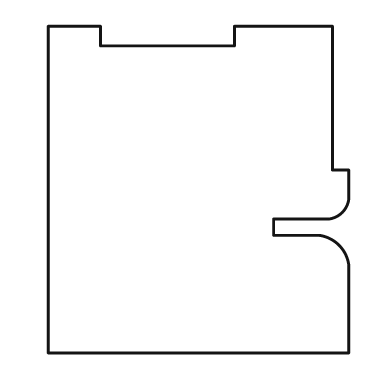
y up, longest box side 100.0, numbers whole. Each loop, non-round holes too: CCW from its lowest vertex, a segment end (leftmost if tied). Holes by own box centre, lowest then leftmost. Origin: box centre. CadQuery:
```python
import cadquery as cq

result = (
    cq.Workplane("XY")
    .moveTo(-46.0, -50.0)
    .lineTo(46.0, -50.0)
    .lineTo(46.0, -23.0)
    .threePointArc((43.0, -17.0), (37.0, -14.0))
    .lineTo(23.0, -14.0)
    .lineTo(23.0, -9.0)
    .lineTo(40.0, -9.0)
    .threePointArc((44.0, -7.0), (46.0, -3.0))
    .lineTo(46.0, 6.0)
    .lineTo(41.0, 6.0)
    .lineTo(41.0, 50.0)
    .lineTo(11.0, 50.0)
    .lineTo(11.0, 44.0)
    .lineTo(-30.0, 44.0)
    .lineTo(-30.0, 50.0)
    .lineTo(-46.0, 50.0)
    .close()
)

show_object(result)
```